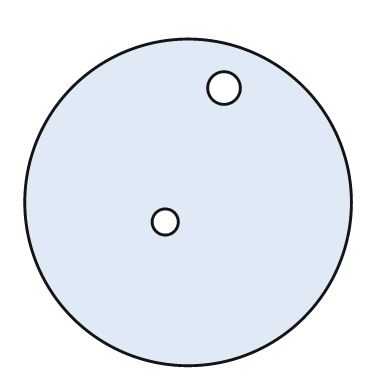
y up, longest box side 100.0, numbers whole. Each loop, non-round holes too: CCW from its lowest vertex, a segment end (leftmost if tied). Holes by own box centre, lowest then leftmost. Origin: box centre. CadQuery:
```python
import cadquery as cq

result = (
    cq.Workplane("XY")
    .moveTo(0.0, 0.0)
    .circle(50.0)
    .moveTo(-7.0, -6.0)
    .circle(4.0)
    .moveTo(11.0, 35.0)
    .circle(5.0)
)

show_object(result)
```